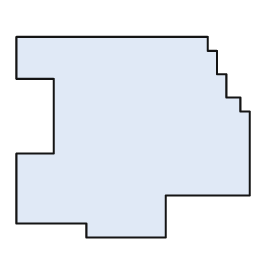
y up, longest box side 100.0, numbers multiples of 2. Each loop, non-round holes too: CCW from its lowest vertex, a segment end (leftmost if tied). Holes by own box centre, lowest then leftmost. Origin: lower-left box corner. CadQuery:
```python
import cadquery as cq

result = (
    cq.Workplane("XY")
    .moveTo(30.0, 0.0)
    .lineTo(64.0, 0.0)
    .lineTo(64.0, 18.0)
    .lineTo(100.0, 18.0)
    .lineTo(100.0, 54.0)
    .lineTo(96.0, 54.0)
    .lineTo(96.0, 60.0)
    .lineTo(90.0, 60.0)
    .lineTo(90.0, 70.0)
    .lineTo(86.0, 70.0)
    .lineTo(86.0, 80.0)
    .lineTo(82.0, 80.0)
    .lineTo(82.0, 86.0)
    .lineTo(0.0, 86.0)
    .lineTo(0.0, 68.0)
    .lineTo(16.0, 68.0)
    .lineTo(16.0, 36.0)
    .lineTo(0.0, 36.0)
    .lineTo(0.0, 6.0)
    .lineTo(30.0, 6.0)
    .close()
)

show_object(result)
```